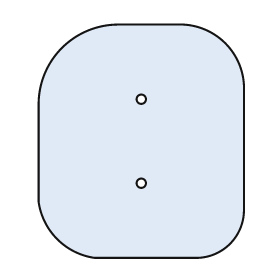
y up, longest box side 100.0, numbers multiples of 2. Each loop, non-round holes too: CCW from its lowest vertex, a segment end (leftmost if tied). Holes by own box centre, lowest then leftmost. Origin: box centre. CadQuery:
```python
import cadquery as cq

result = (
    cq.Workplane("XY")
    .moveTo(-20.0, -50.0)
    .lineTo(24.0, -50.0)
    .threePointArc((38.0, -44.0), (44.0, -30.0))
    .lineTo(44.0, 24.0)
    .threePointArc((36.0, 42.0), (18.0, 50.0))
    .lineTo(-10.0, 50.0)
    .threePointArc((-34.0, 40.0), (-44.0, 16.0))
    .lineTo(-44.0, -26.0)
    .threePointArc((-36.0, -42.0), (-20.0, -50.0))
    .close()
    .moveTo(0.0, -18.0)
    .circle(2.0)
    .moveTo(0.0, 18.0)
    .circle(2.0)
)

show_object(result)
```